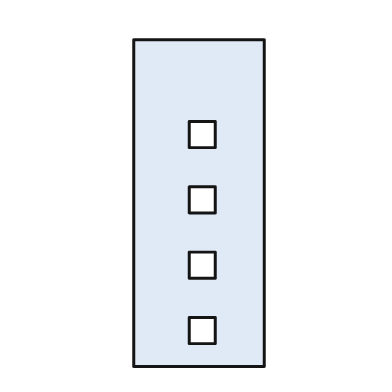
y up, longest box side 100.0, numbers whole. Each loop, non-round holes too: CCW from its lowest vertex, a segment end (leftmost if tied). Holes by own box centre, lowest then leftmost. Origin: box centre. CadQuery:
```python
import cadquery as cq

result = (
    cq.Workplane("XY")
    .moveTo(-20.0, -50.0)
    .lineTo(20.0, -50.0)
    .lineTo(20.0, 50.0)
    .lineTo(-20.0, 50.0)
    .close()
    .moveTo(-3.0, -43.0)
    .lineTo(5.0, -43.0)
    .lineTo(5.0, -35.0)
    .lineTo(-3.0, -35.0)
    .close()
    .moveTo(-3.0, -23.0)
    .lineTo(5.0, -23.0)
    .lineTo(5.0, -15.0)
    .lineTo(-3.0, -15.0)
    .close()
    .moveTo(-3.0, -3.0)
    .lineTo(5.0, -3.0)
    .lineTo(5.0, 5.0)
    .lineTo(-3.0, 5.0)
    .close()
    .moveTo(-3.0, 17.0)
    .lineTo(5.0, 17.0)
    .lineTo(5.0, 25.0)
    .lineTo(-3.0, 25.0)
    .close()
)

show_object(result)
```